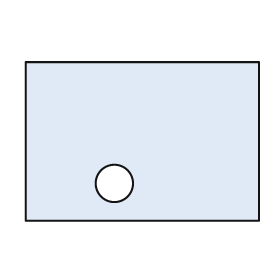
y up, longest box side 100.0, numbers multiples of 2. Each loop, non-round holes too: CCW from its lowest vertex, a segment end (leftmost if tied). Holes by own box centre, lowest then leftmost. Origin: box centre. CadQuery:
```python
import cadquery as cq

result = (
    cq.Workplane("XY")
    .moveTo(-50.0, -34.0)
    .lineTo(50.0, -34.0)
    .lineTo(50.0, 34.0)
    .lineTo(-50.0, 34.0)
    .close()
    .moveTo(-12.0, -18.0)
    .circle(8.0)
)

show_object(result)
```